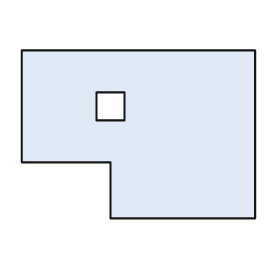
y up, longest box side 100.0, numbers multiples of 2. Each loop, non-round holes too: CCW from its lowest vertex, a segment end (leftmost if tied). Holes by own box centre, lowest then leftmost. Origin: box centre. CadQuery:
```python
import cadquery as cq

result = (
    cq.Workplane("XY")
    .moveTo(-12.0, -36.0)
    .lineTo(50.0, -36.0)
    .lineTo(50.0, 36.0)
    .lineTo(-50.0, 36.0)
    .lineTo(-50.0, -12.0)
    .lineTo(-12.0, -12.0)
    .close()
    .moveTo(-18.0, 6.0)
    .lineTo(-6.0, 6.0)
    .lineTo(-6.0, 18.0)
    .lineTo(-18.0, 18.0)
    .close()
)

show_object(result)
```